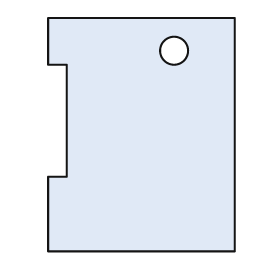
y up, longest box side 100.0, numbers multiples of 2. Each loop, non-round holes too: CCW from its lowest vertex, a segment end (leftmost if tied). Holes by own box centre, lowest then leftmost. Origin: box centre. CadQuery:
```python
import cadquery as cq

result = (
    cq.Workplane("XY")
    .moveTo(-40.0, -50.0)
    .lineTo(40.0, -50.0)
    .lineTo(40.0, 50.0)
    .lineTo(-40.0, 50.0)
    .lineTo(-40.0, 30.0)
    .lineTo(-32.0, 30.0)
    .lineTo(-32.0, -18.0)
    .lineTo(-40.0, -18.0)
    .close()
    .moveTo(14.0, 36.0)
    .circle(6.0)
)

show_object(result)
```